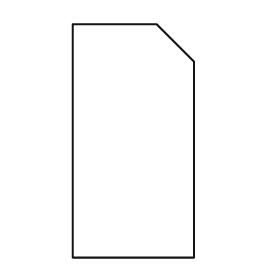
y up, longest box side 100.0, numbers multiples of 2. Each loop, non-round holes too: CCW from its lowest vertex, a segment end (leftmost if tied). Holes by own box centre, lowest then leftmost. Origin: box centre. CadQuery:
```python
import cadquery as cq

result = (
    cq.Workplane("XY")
    .moveTo(-26.0, -50.0)
    .lineTo(26.0, -50.0)
    .lineTo(26.0, 34.0)
    .lineTo(10.0, 50.0)
    .lineTo(-26.0, 50.0)
    .close()
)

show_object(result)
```